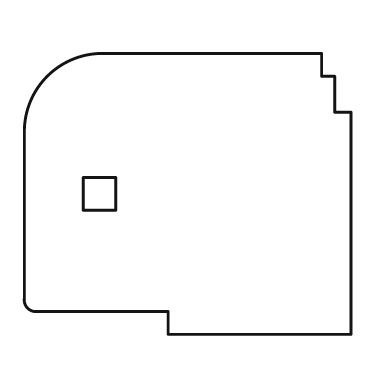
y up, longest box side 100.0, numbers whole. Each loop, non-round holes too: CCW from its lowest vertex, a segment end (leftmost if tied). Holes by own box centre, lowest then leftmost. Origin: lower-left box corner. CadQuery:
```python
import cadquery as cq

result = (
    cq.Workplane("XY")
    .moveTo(44.0, 0.0)
    .lineTo(100.0, 0.0)
    .lineTo(100.0, 68.0)
    .lineTo(95.0, 68.0)
    .lineTo(95.0, 79.0)
    .lineTo(91.0, 79.0)
    .lineTo(91.0, 86.0)
    .lineTo(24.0, 86.0)
    .threePointArc((7.0, 79.0), (0.0, 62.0))
    .lineTo(0.0, 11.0)
    .threePointArc((1.0, 8.0), (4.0, 7.0))
    .lineTo(44.0, 7.0)
    .close()
    .moveTo(18.0, 38.0)
    .lineTo(28.0, 38.0)
    .lineTo(28.0, 48.0)
    .lineTo(18.0, 48.0)
    .close()
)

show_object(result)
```